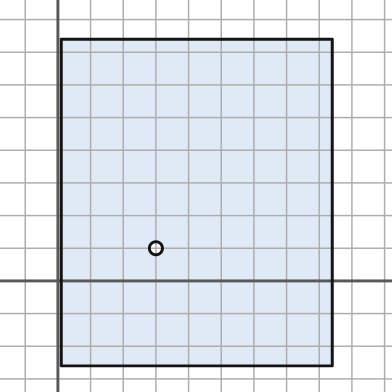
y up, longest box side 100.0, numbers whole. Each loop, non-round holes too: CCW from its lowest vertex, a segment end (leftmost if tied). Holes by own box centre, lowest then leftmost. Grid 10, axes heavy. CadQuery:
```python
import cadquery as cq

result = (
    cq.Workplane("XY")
    .moveTo(1.0, -26.0)
    .lineTo(84.0, -26.0)
    .lineTo(84.0, 74.0)
    .lineTo(1.0, 74.0)
    .close()
    .moveTo(30.0, 10.0)
    .circle(2.0)
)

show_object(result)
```